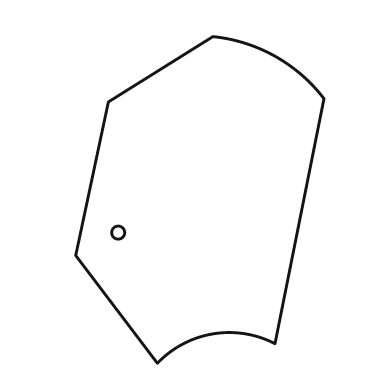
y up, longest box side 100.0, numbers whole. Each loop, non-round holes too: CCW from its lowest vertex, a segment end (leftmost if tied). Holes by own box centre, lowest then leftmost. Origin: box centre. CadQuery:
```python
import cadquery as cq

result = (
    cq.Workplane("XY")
    .moveTo(-13.0, -50.0)
    .threePointArc((4.0, -41.0), (23.0, -44.0))
    .lineTo(38.0, 31.0)
    .threePointArc((23.0, 44.0), (4.0, 50.0))
    .lineTo(-28.0, 30.0)
    .lineTo(-38.0, -17.0)
    .close()
    .moveTo(-25.0, -10.0)
    .circle(2.0)
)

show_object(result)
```